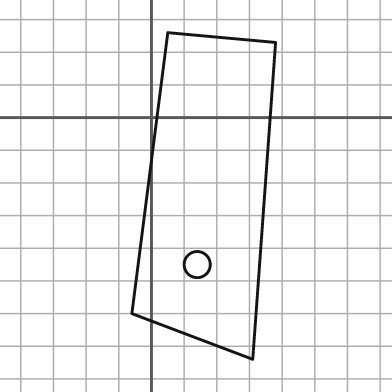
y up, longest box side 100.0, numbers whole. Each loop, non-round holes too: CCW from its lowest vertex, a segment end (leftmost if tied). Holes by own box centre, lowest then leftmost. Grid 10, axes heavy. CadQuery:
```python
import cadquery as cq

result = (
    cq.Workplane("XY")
    .moveTo(31.0, -74.0)
    .lineTo(38.0, 23.0)
    .lineTo(5.0, 26.0)
    .lineTo(-6.0, -60.0)
    .close()
    .moveTo(14.0, -45.0)
    .circle(4.0)
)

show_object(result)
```